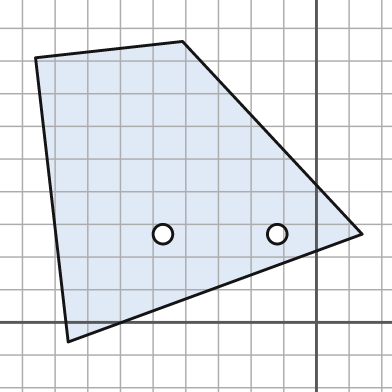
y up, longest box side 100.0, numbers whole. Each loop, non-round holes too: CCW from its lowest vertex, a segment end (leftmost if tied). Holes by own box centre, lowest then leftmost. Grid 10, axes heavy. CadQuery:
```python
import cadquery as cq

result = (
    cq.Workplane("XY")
    .moveTo(-76.0, -6.0)
    .lineTo(14.0, 27.0)
    .lineTo(-41.0, 86.0)
    .lineTo(-86.0, 81.0)
    .close()
    .moveTo(-47.0, 27.0)
    .circle(3.0)
    .moveTo(-12.0, 27.0)
    .circle(3.0)
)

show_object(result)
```